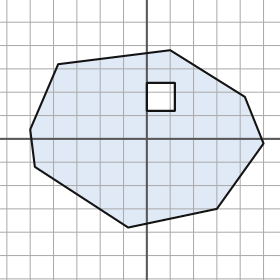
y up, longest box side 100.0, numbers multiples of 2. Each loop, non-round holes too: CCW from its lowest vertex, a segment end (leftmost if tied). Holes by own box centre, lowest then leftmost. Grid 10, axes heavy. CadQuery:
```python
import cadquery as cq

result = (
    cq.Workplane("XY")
    .moveTo(-8.0, -38.0)
    .lineTo(30.0, -30.0)
    .lineTo(50.0, -2.0)
    .lineTo(42.0, 18.0)
    .lineTo(10.0, 38.0)
    .lineTo(-38.0, 32.0)
    .lineTo(-50.0, 4.0)
    .lineTo(-48.0, -12.0)
    .close()
    .moveTo(0.0, 12.0)
    .lineTo(12.0, 12.0)
    .lineTo(12.0, 24.0)
    .lineTo(0.0, 24.0)
    .close()
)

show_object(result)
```